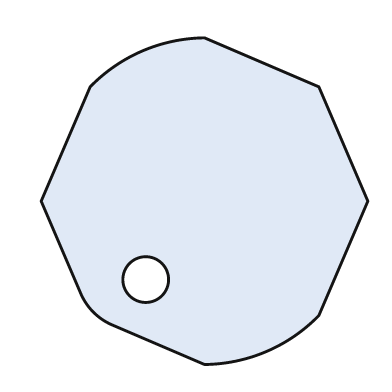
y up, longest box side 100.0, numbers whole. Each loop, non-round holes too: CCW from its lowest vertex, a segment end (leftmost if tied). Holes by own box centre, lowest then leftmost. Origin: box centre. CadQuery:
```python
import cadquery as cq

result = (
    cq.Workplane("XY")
    .moveTo(0.0, -50.0)
    .threePointArc((19.0, -46.0), (35.0, -35.0))
    .lineTo(50.0, 0.0)
    .lineTo(35.0, 35.0)
    .lineTo(0.0, 50.0)
    .threePointArc((-19.0, 46.0), (-35.0, 35.0))
    .lineTo(-50.0, 0.0)
    .lineTo(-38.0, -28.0)
    .threePointArc((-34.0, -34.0), (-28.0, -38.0))
    .close()
    .moveTo(-18.0, -24.0)
    .circle(7.0)
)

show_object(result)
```